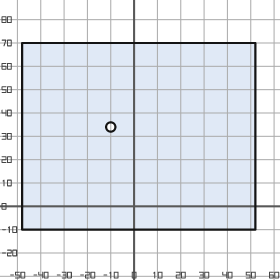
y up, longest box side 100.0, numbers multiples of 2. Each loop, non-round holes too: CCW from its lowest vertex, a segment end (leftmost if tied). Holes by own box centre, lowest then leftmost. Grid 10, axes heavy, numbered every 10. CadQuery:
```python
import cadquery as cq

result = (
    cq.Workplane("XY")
    .moveTo(-48.0, -10.0)
    .lineTo(52.0, -10.0)
    .lineTo(52.0, 70.0)
    .lineTo(-48.0, 70.0)
    .close()
    .moveTo(-10.0, 34.0)
    .circle(2.0)
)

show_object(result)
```